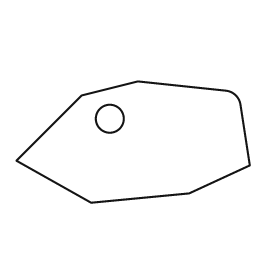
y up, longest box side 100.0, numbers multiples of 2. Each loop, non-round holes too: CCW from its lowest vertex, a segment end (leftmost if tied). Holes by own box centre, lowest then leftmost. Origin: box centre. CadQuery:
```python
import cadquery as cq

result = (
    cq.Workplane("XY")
    .moveTo(-18.0, -26.0)
    .lineTo(24.0, -22.0)
    .lineTo(50.0, -10.0)
    .lineTo(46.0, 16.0)
    .threePointArc((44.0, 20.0), (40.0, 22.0))
    .lineTo(2.0, 26.0)
    .lineTo(-22.0, 20.0)
    .lineTo(-50.0, -8.0)
    .close()
    .moveTo(-10.0, 10.0)
    .circle(6.0)
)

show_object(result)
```